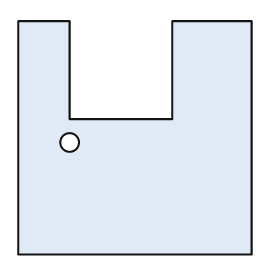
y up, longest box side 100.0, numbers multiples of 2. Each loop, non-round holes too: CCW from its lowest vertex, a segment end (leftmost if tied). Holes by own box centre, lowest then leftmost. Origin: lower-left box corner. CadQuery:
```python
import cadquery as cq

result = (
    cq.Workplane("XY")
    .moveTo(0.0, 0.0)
    .lineTo(100.0, 0.0)
    .lineTo(100.0, 100.0)
    .lineTo(66.0, 100.0)
    .lineTo(66.0, 58.0)
    .lineTo(22.0, 58.0)
    .lineTo(22.0, 100.0)
    .lineTo(0.0, 100.0)
    .close()
    .moveTo(22.0, 48.0)
    .circle(4.0)
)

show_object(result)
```